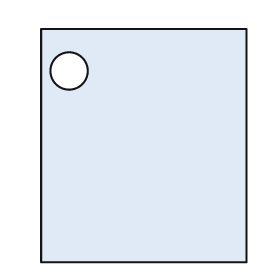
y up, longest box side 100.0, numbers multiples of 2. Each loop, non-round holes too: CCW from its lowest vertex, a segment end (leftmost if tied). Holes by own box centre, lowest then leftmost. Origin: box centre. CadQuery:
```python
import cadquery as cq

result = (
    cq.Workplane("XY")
    .moveTo(-44.0, -50.0)
    .lineTo(44.0, -50.0)
    .lineTo(44.0, 50.0)
    .lineTo(-44.0, 50.0)
    .close()
    .moveTo(-32.0, 32.0)
    .circle(8.0)
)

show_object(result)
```